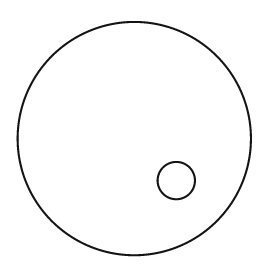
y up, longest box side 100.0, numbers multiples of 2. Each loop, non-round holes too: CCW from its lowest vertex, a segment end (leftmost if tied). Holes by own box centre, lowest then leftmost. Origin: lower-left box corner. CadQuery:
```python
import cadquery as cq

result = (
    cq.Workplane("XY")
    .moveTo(50.0, 50.0)
    .circle(50.0)
    .moveTo(68.0, 32.0)
    .circle(8.0)
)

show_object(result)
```